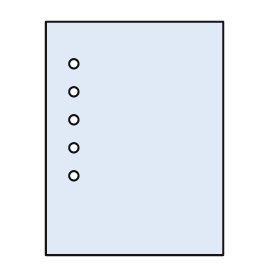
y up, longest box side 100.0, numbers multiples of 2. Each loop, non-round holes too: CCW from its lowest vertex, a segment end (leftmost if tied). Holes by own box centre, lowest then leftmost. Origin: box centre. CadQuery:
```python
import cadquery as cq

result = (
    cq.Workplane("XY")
    .moveTo(-38.0, -50.0)
    .lineTo(38.0, -50.0)
    .lineTo(38.0, 50.0)
    .lineTo(-38.0, 50.0)
    .close()
    .moveTo(-26.0, -16.0)
    .circle(2.0)
    .moveTo(-26.0, -4.0)
    .circle(2.0)
    .moveTo(-26.0, 8.0)
    .circle(2.0)
    .moveTo(-26.0, 20.0)
    .circle(2.0)
    .moveTo(-26.0, 32.0)
    .circle(2.0)
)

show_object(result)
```